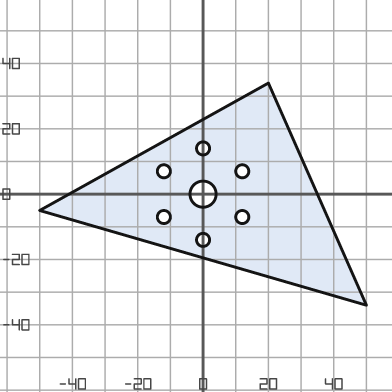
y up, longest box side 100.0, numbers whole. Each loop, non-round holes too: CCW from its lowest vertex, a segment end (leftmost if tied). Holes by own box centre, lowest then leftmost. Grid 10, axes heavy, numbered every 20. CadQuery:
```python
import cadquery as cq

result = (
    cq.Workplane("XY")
    .moveTo(50.0, -34.0)
    .lineTo(20.0, 34.0)
    .lineTo(-50.0, -5.0)
    .close()
    .moveTo(0.0, -14.0)
    .circle(2.0)
    .moveTo(-12.0, -7.0)
    .circle(2.0)
    .moveTo(12.0, -7.0)
    .circle(2.0)
    .moveTo(0.0, 0.0)
    .circle(4.0)
    .moveTo(-12.0, 7.0)
    .circle(2.0)
    .moveTo(12.0, 7.0)
    .circle(2.0)
    .moveTo(0.0, 14.0)
    .circle(2.0)
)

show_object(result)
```